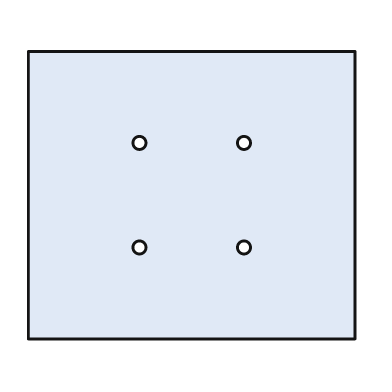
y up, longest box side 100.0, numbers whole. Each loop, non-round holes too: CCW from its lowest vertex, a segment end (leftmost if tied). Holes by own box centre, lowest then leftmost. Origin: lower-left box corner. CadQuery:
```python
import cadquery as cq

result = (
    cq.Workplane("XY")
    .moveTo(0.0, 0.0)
    .lineTo(100.0, 0.0)
    .lineTo(100.0, 88.0)
    .lineTo(0.0, 88.0)
    .close()
    .moveTo(34.0, 28.0)
    .circle(2.0)
    .moveTo(66.0, 28.0)
    .circle(2.0)
    .moveTo(34.0, 60.0)
    .circle(2.0)
    .moveTo(66.0, 60.0)
    .circle(2.0)
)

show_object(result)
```